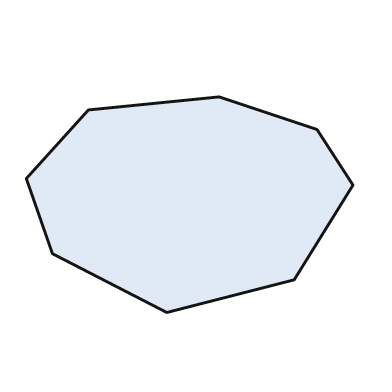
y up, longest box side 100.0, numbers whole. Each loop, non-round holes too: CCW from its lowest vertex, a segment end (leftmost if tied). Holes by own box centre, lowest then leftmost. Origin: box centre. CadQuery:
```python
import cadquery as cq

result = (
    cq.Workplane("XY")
    .moveTo(-7.0, -33.0)
    .lineTo(32.0, -23.0)
    .lineTo(50.0, 6.0)
    .lineTo(39.0, 23.0)
    .lineTo(9.0, 33.0)
    .lineTo(-31.0, 29.0)
    .lineTo(-50.0, 8.0)
    .lineTo(-42.0, -15.0)
    .close()
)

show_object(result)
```